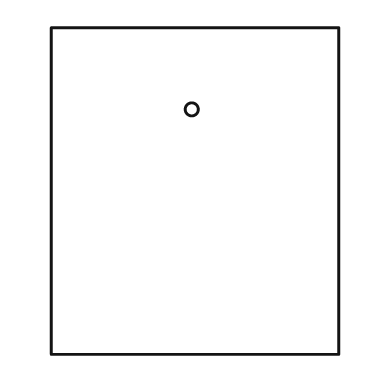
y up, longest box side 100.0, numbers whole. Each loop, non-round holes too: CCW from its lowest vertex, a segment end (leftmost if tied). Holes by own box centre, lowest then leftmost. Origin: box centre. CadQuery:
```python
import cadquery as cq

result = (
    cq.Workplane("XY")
    .moveTo(-44.0, -50.0)
    .lineTo(44.0, -50.0)
    .lineTo(44.0, 50.0)
    .lineTo(-44.0, 50.0)
    .close()
    .moveTo(-1.0, 25.0)
    .circle(2.0)
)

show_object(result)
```